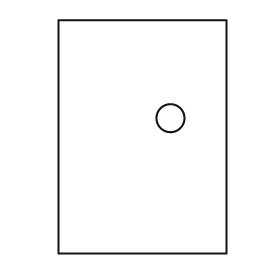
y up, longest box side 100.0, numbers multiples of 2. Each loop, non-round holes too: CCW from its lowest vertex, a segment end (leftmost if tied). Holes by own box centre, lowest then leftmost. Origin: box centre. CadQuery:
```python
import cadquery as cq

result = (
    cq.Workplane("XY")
    .moveTo(-36.0, -50.0)
    .lineTo(36.0, -50.0)
    .lineTo(36.0, 50.0)
    .lineTo(-36.0, 50.0)
    .close()
    .moveTo(12.0, 8.0)
    .circle(6.0)
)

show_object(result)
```